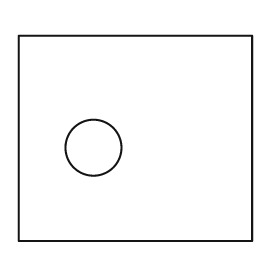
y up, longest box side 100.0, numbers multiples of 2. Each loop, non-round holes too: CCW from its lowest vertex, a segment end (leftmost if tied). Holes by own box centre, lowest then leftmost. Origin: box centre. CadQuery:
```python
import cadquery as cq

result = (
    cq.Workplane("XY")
    .moveTo(-50.0, -44.0)
    .lineTo(50.0, -44.0)
    .lineTo(50.0, 44.0)
    .lineTo(-50.0, 44.0)
    .close()
    .moveTo(-18.0, -4.0)
    .circle(12.0)
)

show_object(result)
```